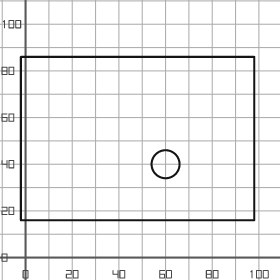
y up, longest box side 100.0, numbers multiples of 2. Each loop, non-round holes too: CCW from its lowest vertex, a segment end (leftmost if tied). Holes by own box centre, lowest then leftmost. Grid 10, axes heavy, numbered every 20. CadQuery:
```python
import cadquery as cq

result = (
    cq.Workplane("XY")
    .moveTo(-2.0, 16.0)
    .lineTo(98.0, 16.0)
    .lineTo(98.0, 86.0)
    .lineTo(-2.0, 86.0)
    .close()
    .moveTo(60.0, 40.0)
    .circle(6.0)
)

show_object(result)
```